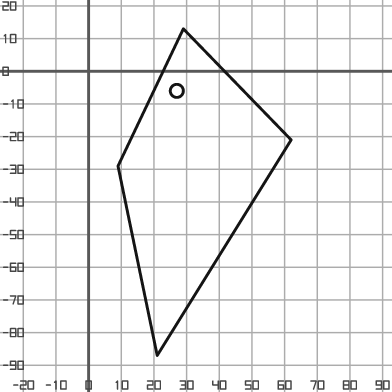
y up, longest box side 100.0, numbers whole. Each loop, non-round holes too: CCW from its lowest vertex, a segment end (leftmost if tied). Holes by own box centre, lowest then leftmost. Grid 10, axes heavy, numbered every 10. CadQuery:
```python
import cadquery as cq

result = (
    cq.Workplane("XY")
    .moveTo(21.0, -87.0)
    .lineTo(62.0, -21.0)
    .lineTo(29.0, 13.0)
    .lineTo(9.0, -29.0)
    .close()
    .moveTo(27.0, -6.0)
    .circle(2.0)
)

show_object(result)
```